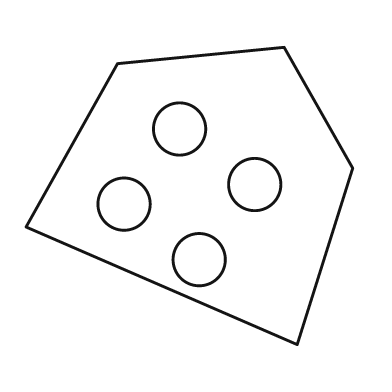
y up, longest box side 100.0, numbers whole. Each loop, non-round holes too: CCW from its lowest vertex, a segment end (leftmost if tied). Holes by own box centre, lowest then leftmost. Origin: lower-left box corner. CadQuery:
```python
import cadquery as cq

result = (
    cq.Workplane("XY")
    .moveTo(83.0, 0.0)
    .lineTo(100.0, 54.0)
    .lineTo(79.0, 91.0)
    .lineTo(28.0, 86.0)
    .lineTo(0.0, 36.0)
    .close()
    .moveTo(53.0, 26.0)
    .circle(8.0)
    .moveTo(30.0, 43.0)
    .circle(8.0)
    .moveTo(70.0, 49.0)
    .circle(8.0)
    .moveTo(47.0, 66.0)
    .circle(8.0)
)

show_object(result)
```